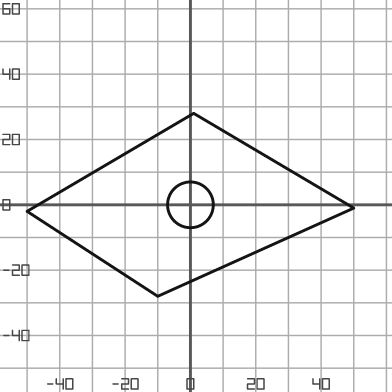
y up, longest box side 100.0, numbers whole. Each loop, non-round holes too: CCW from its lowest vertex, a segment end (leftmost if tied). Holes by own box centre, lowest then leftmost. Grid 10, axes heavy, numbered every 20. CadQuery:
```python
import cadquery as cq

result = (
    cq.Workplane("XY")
    .moveTo(-10.0, -28.0)
    .lineTo(50.0, -1.0)
    .lineTo(1.0, 28.0)
    .lineTo(-50.0, -2.0)
    .close()
    .moveTo(0.0, 0.0)
    .circle(7.0)
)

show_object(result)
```